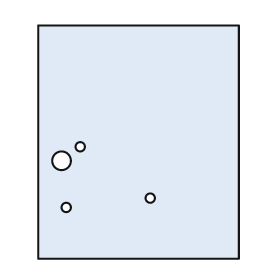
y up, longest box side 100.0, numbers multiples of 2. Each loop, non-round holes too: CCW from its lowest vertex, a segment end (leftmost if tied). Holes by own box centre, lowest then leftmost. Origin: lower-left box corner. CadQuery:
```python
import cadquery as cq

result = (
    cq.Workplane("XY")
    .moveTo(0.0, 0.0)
    .lineTo(86.0, 0.0)
    .lineTo(86.0, 100.0)
    .lineTo(0.0, 100.0)
    .close()
    .moveTo(12.0, 22.0)
    .circle(2.0)
    .moveTo(48.0, 26.0)
    .circle(2.0)
    .moveTo(10.0, 42.0)
    .circle(4.0)
    .moveTo(18.0, 48.0)
    .circle(2.0)
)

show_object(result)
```